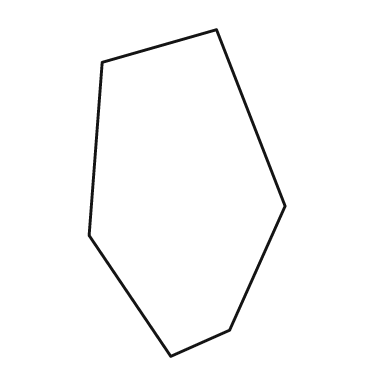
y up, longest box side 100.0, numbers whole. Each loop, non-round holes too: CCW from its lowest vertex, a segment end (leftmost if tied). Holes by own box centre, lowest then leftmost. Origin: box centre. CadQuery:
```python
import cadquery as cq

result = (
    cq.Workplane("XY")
    .moveTo(-5.0, -50.0)
    .lineTo(13.0, -42.0)
    .lineTo(30.0, -4.0)
    .lineTo(9.0, 50.0)
    .lineTo(-26.0, 40.0)
    .lineTo(-30.0, -13.0)
    .close()
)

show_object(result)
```